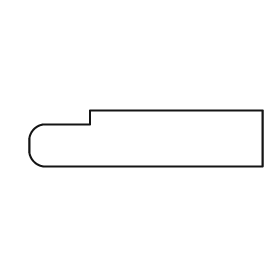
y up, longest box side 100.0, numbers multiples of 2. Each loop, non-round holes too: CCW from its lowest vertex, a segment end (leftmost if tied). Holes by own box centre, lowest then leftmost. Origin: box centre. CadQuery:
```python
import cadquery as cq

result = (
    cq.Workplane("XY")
    .moveTo(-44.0, -12.0)
    .lineTo(50.0, -12.0)
    .lineTo(50.0, 12.0)
    .lineTo(-24.0, 12.0)
    .lineTo(-24.0, 6.0)
    .lineTo(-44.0, 6.0)
    .threePointArc((-48.0, 4.0), (-50.0, 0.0))
    .lineTo(-50.0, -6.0)
    .threePointArc((-48.0, -10.0), (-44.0, -12.0))
    .close()
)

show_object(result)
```